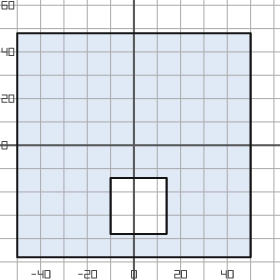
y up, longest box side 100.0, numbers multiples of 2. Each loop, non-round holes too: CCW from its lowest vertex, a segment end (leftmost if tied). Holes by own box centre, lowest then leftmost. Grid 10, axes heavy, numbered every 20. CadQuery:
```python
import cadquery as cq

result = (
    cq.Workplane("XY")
    .moveTo(-50.0, -48.0)
    .lineTo(50.0, -48.0)
    .lineTo(50.0, 48.0)
    .lineTo(-50.0, 48.0)
    .close()
    .moveTo(-10.0, -38.0)
    .lineTo(14.0, -38.0)
    .lineTo(14.0, -14.0)
    .lineTo(-10.0, -14.0)
    .close()
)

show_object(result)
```